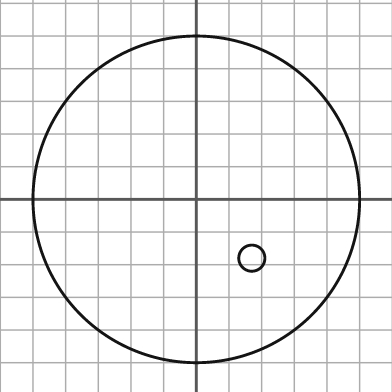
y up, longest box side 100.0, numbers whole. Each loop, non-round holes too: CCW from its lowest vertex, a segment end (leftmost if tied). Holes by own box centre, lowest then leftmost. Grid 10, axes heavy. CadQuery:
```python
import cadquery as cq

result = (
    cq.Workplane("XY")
    .moveTo(0.0, 0.0)
    .circle(50.0)
    .moveTo(17.0, -18.0)
    .circle(4.0)
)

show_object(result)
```